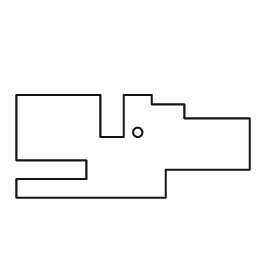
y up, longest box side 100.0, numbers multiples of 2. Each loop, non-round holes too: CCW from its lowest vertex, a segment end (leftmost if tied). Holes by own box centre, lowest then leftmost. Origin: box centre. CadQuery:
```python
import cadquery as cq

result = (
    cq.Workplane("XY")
    .moveTo(-50.0, -22.0)
    .lineTo(14.0, -22.0)
    .lineTo(14.0, -10.0)
    .lineTo(50.0, -10.0)
    .lineTo(50.0, 12.0)
    .lineTo(22.0, 12.0)
    .lineTo(22.0, 18.0)
    .lineTo(8.0, 18.0)
    .lineTo(8.0, 22.0)
    .lineTo(-4.0, 22.0)
    .lineTo(-4.0, 4.0)
    .lineTo(-14.0, 4.0)
    .lineTo(-14.0, 22.0)
    .lineTo(-50.0, 22.0)
    .lineTo(-50.0, -6.0)
    .lineTo(-20.0, -6.0)
    .lineTo(-20.0, -14.0)
    .lineTo(-50.0, -14.0)
    .close()
    .moveTo(2.0, 6.0)
    .circle(2.0)
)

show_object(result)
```